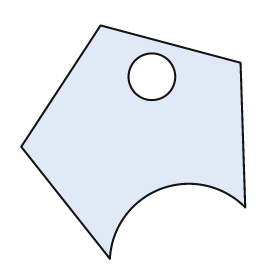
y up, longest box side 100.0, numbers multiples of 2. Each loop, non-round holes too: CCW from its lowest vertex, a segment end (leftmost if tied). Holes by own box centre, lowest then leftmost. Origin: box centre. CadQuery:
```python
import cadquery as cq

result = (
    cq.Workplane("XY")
    .moveTo(-10.0, -50.0)
    .threePointArc((12.0, -20.0), (48.0, -28.0))
    .lineTo(46.0, 34.0)
    .lineTo(-14.0, 50.0)
    .lineTo(-48.0, -2.0)
    .close()
    .moveTo(8.0, 28.0)
    .circle(10.0)
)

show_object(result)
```